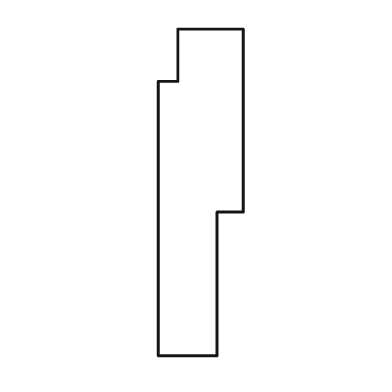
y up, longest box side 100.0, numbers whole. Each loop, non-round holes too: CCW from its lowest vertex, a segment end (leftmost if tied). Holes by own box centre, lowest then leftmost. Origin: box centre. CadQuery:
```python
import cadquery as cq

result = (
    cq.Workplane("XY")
    .moveTo(-13.0, -50.0)
    .lineTo(5.0, -50.0)
    .lineTo(5.0, -6.0)
    .lineTo(13.0, -6.0)
    .lineTo(13.0, 50.0)
    .lineTo(-7.0, 50.0)
    .lineTo(-7.0, 34.0)
    .lineTo(-13.0, 34.0)
    .close()
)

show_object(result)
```